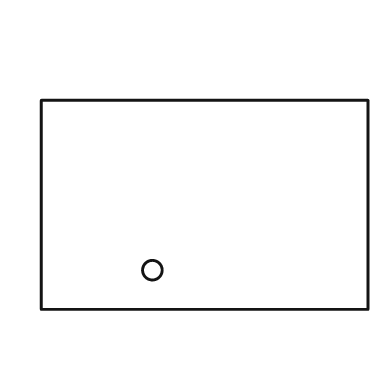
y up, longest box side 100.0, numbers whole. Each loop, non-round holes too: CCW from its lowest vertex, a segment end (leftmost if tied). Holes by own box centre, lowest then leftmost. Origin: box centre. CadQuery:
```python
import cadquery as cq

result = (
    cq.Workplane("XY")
    .moveTo(-50.0, -32.0)
    .lineTo(50.0, -32.0)
    .lineTo(50.0, 32.0)
    .lineTo(-50.0, 32.0)
    .close()
    .moveTo(-16.0, -20.0)
    .circle(3.0)
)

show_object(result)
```